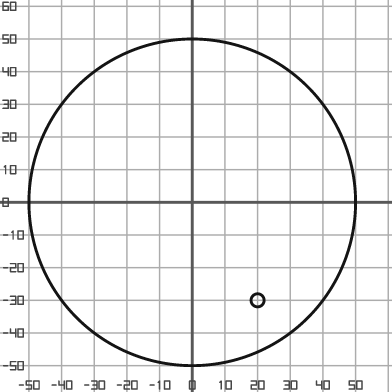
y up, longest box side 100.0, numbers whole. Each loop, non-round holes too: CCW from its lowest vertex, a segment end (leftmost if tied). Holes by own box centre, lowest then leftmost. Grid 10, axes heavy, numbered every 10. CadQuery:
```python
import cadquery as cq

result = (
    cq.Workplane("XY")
    .moveTo(0.0, 0.0)
    .circle(50.0)
    .moveTo(20.0, -30.0)
    .circle(2.0)
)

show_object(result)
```